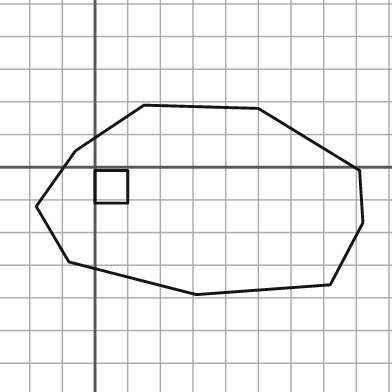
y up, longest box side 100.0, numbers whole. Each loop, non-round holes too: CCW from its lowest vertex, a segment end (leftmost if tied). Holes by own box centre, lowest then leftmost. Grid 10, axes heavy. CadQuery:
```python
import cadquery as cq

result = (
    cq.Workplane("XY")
    .moveTo(31.0, -39.0)
    .lineTo(72.0, -36.0)
    .lineTo(82.0, -17.0)
    .lineTo(81.0, -1.0)
    .lineTo(50.0, 18.0)
    .lineTo(15.0, 19.0)
    .lineTo(-6.0, 5.0)
    .lineTo(-18.0, -12.0)
    .lineTo(-8.0, -29.0)
    .close()
    .moveTo(0.0, -11.0)
    .lineTo(10.0, -11.0)
    .lineTo(10.0, -1.0)
    .lineTo(0.0, -1.0)
    .close()
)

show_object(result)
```